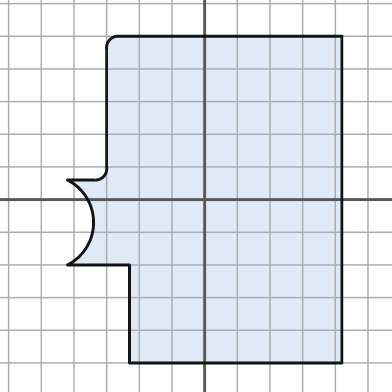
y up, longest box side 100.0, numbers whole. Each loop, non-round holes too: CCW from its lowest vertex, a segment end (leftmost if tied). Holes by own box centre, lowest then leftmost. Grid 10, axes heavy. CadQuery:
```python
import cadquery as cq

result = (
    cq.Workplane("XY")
    .moveTo(-23.0, -50.0)
    .lineTo(42.0, -50.0)
    .lineTo(42.0, 50.0)
    .lineTo(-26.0, 50.0)
    .threePointArc((-29.0, 49.0), (-30.0, 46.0))
    .lineTo(-30.0, 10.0)
    .threePointArc((-31.0, 7.0), (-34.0, 6.0))
    .lineTo(-42.0, 6.0)
    .threePointArc((-34.0, -7.0), (-42.0, -20.0))
    .lineTo(-23.0, -20.0)
    .close()
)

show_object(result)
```